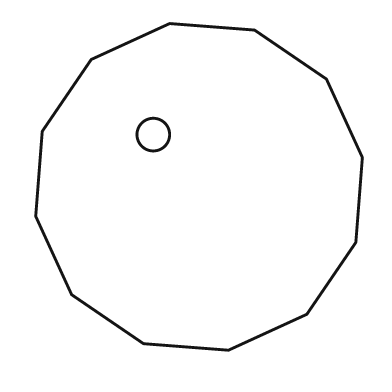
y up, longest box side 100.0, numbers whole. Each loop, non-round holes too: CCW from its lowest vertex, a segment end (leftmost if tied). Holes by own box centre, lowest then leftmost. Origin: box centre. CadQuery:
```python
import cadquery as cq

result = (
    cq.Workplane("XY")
    .moveTo(9.0, -50.0)
    .lineTo(33.0, -39.0)
    .lineTo(48.0, -17.0)
    .lineTo(50.0, 9.0)
    .lineTo(39.0, 33.0)
    .lineTo(17.0, 48.0)
    .lineTo(-9.0, 50.0)
    .lineTo(-33.0, 39.0)
    .lineTo(-48.0, 17.0)
    .lineTo(-50.0, -9.0)
    .lineTo(-39.0, -33.0)
    .lineTo(-17.0, -48.0)
    .close()
    .moveTo(-14.0, 16.0)
    .circle(5.0)
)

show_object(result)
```